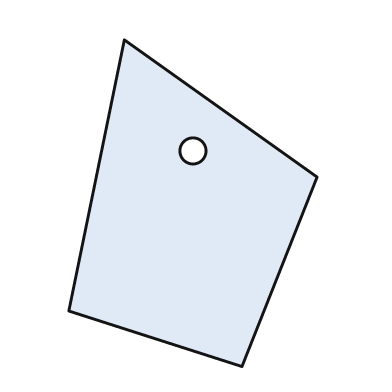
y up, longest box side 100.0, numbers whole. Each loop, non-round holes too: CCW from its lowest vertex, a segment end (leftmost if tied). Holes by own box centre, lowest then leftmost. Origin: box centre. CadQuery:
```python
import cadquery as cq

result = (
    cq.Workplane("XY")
    .moveTo(15.0, -50.0)
    .lineTo(38.0, 8.0)
    .lineTo(-21.0, 50.0)
    .lineTo(-38.0, -33.0)
    .close()
    .moveTo(0.0, 16.0)
    .circle(4.0)
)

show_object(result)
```